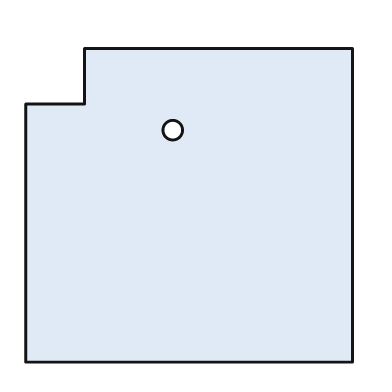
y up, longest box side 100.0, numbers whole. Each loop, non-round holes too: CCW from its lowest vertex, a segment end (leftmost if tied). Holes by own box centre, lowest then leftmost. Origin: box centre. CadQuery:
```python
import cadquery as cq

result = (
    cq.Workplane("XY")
    .moveTo(-50.0, -48.0)
    .lineTo(50.0, -48.0)
    .lineTo(50.0, 48.0)
    .lineTo(-32.0, 48.0)
    .lineTo(-32.0, 31.0)
    .lineTo(-50.0, 31.0)
    .close()
    .moveTo(-5.0, 23.0)
    .circle(3.0)
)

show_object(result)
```